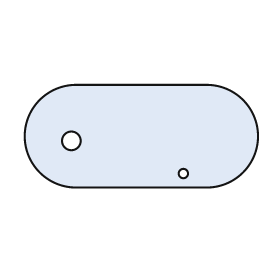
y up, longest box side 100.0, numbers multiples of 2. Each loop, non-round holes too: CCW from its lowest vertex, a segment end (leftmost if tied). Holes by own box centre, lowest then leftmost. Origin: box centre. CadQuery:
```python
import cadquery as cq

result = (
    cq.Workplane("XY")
    .moveTo(-28.0, -22.0)
    .lineTo(28.0, -22.0)
    .threePointArc((50.0, 0.0), (28.0, 22.0))
    .lineTo(-28.0, 22.0)
    .threePointArc((-50.0, 0.0), (-28.0, -22.0))
    .close()
    .moveTo(18.0, -16.0)
    .circle(2.0)
    .moveTo(-30.0, -2.0)
    .circle(4.0)
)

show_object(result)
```